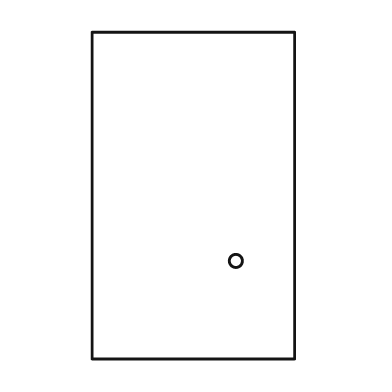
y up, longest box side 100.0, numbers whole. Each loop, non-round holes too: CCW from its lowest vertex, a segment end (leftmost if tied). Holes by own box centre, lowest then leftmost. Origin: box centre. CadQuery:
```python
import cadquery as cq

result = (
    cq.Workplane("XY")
    .moveTo(-31.0, -50.0)
    .lineTo(31.0, -50.0)
    .lineTo(31.0, 50.0)
    .lineTo(-31.0, 50.0)
    .close()
    .moveTo(13.0, -20.0)
    .circle(2.0)
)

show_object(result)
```